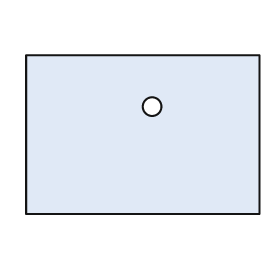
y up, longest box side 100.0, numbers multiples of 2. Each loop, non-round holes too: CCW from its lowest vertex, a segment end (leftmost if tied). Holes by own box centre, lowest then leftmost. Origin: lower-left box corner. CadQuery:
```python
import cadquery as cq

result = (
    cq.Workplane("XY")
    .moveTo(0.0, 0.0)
    .lineTo(100.0, 0.0)
    .lineTo(100.0, 68.0)
    .lineTo(0.0, 68.0)
    .close()
    .moveTo(54.0, 46.0)
    .circle(4.0)
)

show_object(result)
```